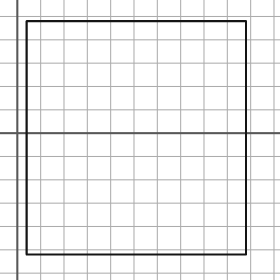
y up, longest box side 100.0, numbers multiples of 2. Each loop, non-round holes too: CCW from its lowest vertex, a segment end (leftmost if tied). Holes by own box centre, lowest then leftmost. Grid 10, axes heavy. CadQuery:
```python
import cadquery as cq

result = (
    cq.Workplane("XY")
    .moveTo(4.0, -52.0)
    .lineTo(98.0, -52.0)
    .lineTo(98.0, 48.0)
    .lineTo(4.0, 48.0)
    .close()
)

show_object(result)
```